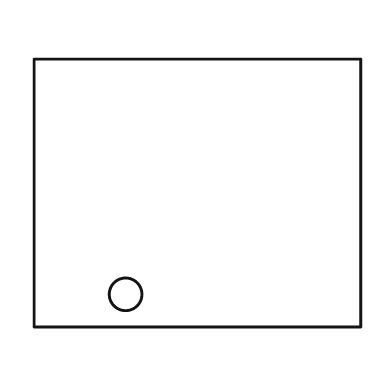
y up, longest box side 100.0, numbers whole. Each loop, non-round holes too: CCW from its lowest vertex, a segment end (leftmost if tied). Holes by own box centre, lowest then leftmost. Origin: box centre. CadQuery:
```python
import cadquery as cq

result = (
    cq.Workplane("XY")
    .moveTo(-50.0, -41.0)
    .lineTo(50.0, -41.0)
    .lineTo(50.0, 41.0)
    .lineTo(-50.0, 41.0)
    .close()
    .moveTo(-22.0, -31.0)
    .circle(5.0)
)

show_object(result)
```